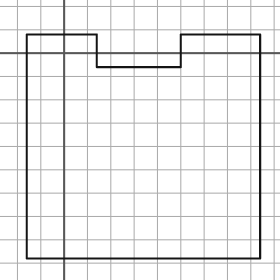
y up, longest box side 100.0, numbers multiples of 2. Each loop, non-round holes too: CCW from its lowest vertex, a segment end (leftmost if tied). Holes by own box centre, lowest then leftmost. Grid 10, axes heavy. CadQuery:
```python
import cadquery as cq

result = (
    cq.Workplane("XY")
    .moveTo(-16.0, -88.0)
    .lineTo(84.0, -88.0)
    .lineTo(84.0, 8.0)
    .lineTo(50.0, 8.0)
    .lineTo(50.0, -6.0)
    .lineTo(14.0, -6.0)
    .lineTo(14.0, 8.0)
    .lineTo(-16.0, 8.0)
    .close()
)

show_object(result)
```